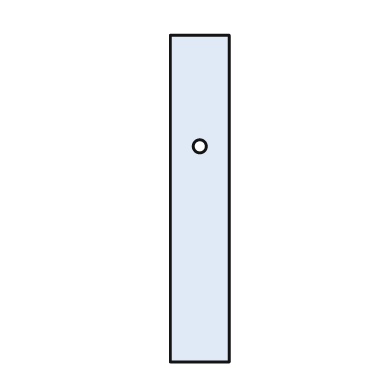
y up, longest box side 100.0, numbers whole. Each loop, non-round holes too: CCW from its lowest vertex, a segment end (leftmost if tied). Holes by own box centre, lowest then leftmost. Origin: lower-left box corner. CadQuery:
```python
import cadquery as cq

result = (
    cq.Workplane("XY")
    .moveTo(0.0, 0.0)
    .lineTo(18.0, 0.0)
    .lineTo(18.0, 100.0)
    .lineTo(0.0, 100.0)
    .close()
    .moveTo(9.0, 66.0)
    .circle(2.0)
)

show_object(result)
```